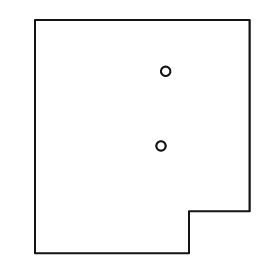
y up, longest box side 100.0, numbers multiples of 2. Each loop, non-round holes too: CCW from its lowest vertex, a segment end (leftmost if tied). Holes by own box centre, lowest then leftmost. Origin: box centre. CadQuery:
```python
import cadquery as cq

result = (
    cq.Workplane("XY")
    .moveTo(-46.0, -50.0)
    .lineTo(20.0, -50.0)
    .lineTo(20.0, -32.0)
    .lineTo(46.0, -32.0)
    .lineTo(46.0, 50.0)
    .lineTo(-46.0, 50.0)
    .close()
    .moveTo(8.0, -4.0)
    .circle(2.0)
    .moveTo(10.0, 28.0)
    .circle(2.0)
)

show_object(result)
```